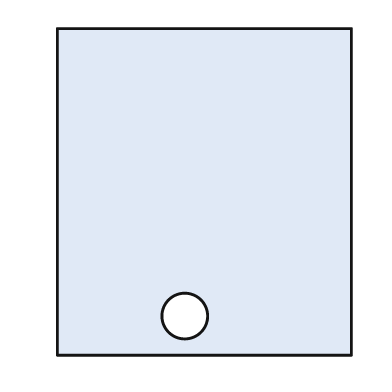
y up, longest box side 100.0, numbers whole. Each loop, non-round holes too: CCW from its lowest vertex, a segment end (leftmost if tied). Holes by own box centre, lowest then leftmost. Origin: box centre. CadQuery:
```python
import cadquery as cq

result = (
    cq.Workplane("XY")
    .moveTo(-45.0, -50.0)
    .lineTo(45.0, -50.0)
    .lineTo(45.0, 50.0)
    .lineTo(-45.0, 50.0)
    .close()
    .moveTo(-6.0, -38.0)
    .circle(7.0)
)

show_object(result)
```